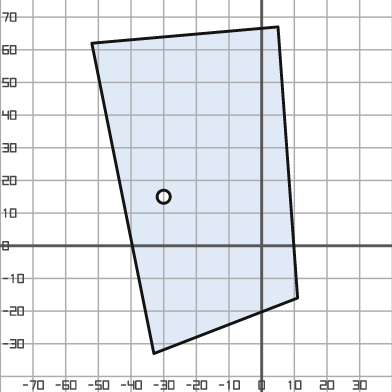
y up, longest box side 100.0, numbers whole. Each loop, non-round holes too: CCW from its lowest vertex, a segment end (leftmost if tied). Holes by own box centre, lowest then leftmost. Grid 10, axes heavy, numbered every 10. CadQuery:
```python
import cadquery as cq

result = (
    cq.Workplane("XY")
    .moveTo(-33.0, -33.0)
    .lineTo(11.0, -16.0)
    .lineTo(5.0, 67.0)
    .lineTo(-52.0, 62.0)
    .close()
    .moveTo(-30.0, 15.0)
    .circle(2.0)
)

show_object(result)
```